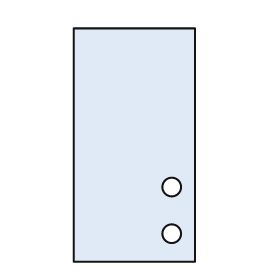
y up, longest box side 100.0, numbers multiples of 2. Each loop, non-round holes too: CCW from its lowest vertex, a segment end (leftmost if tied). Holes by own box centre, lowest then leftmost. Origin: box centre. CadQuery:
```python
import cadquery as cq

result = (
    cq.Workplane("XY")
    .moveTo(-26.0, -50.0)
    .lineTo(26.0, -50.0)
    .lineTo(26.0, 50.0)
    .lineTo(-26.0, 50.0)
    .close()
    .moveTo(16.0, -38.0)
    .circle(4.0)
    .moveTo(16.0, -18.0)
    .circle(4.0)
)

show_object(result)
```